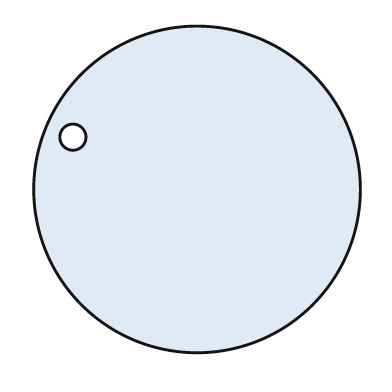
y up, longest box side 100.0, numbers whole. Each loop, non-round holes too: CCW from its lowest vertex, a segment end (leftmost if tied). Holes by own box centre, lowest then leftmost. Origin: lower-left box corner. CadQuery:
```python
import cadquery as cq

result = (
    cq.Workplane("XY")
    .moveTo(50.0, 50.0)
    .circle(50.0)
    .moveTo(12.0, 66.0)
    .circle(4.0)
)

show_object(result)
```